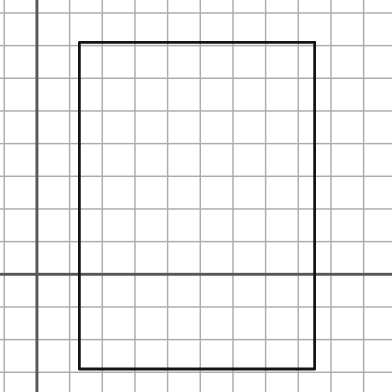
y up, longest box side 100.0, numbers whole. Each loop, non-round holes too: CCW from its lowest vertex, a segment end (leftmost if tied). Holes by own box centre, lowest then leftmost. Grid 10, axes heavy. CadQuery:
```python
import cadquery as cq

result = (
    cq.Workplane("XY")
    .moveTo(13.0, -29.0)
    .lineTo(85.0, -29.0)
    .lineTo(85.0, 71.0)
    .lineTo(13.0, 71.0)
    .close()
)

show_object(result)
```